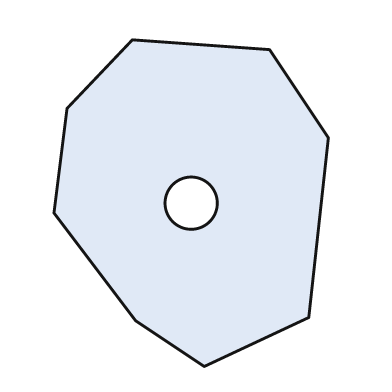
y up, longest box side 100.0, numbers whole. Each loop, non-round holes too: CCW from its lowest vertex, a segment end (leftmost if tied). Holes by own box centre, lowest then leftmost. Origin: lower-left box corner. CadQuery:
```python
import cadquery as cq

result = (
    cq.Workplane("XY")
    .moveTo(46.0, 0.0)
    .lineTo(78.0, 15.0)
    .lineTo(84.0, 70.0)
    .lineTo(66.0, 97.0)
    .lineTo(24.0, 100.0)
    .lineTo(4.0, 79.0)
    .lineTo(0.0, 47.0)
    .lineTo(25.0, 14.0)
    .close()
    .moveTo(42.0, 50.0)
    .circle(8.0)
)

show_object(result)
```